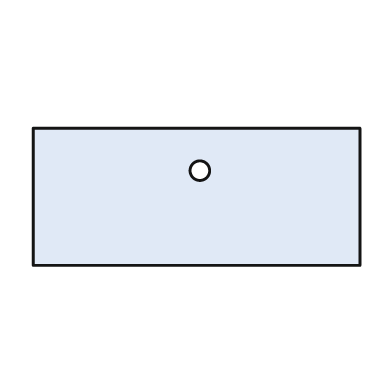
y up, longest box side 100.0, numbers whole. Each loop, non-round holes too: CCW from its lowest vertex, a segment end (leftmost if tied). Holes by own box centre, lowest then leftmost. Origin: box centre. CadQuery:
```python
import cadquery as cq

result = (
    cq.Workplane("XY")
    .moveTo(-50.0, -21.0)
    .lineTo(50.0, -21.0)
    .lineTo(50.0, 21.0)
    .lineTo(-50.0, 21.0)
    .close()
    .moveTo(1.0, 8.0)
    .circle(3.0)
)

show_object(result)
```